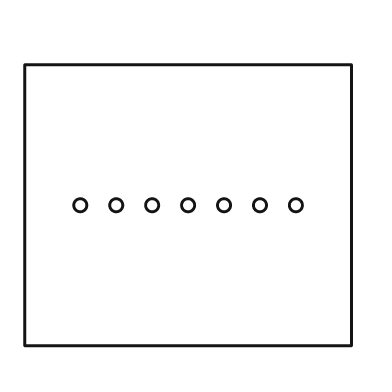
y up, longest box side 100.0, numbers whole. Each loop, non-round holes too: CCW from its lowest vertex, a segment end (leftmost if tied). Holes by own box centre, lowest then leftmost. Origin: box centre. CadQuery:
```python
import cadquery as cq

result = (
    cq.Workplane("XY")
    .moveTo(-50.0, -43.0)
    .lineTo(50.0, -43.0)
    .lineTo(50.0, 43.0)
    .lineTo(-50.0, 43.0)
    .close()
    .moveTo(-33.0, 0.0)
    .circle(2.0)
    .moveTo(-22.0, 0.0)
    .circle(2.0)
    .moveTo(-11.0, 0.0)
    .circle(2.0)
    .moveTo(0.0, 0.0)
    .circle(2.0)
    .moveTo(11.0, 0.0)
    .circle(2.0)
    .moveTo(22.0, 0.0)
    .circle(2.0)
    .moveTo(33.0, 0.0)
    .circle(2.0)
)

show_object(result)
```